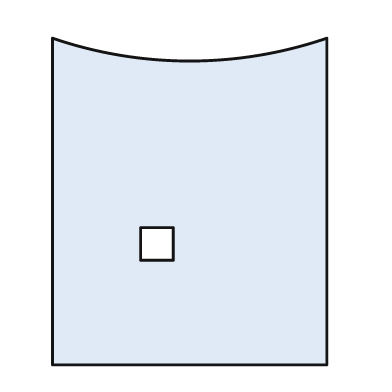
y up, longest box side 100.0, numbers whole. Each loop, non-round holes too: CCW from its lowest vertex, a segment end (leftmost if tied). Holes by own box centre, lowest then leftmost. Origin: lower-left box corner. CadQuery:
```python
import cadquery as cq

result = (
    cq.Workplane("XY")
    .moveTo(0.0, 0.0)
    .lineTo(84.0, 0.0)
    .lineTo(84.0, 100.0)
    .threePointArc((42.0, 93.0), (0.0, 100.0))
    .close()
    .moveTo(27.0, 32.0)
    .lineTo(37.0, 32.0)
    .lineTo(37.0, 42.0)
    .lineTo(27.0, 42.0)
    .close()
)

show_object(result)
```